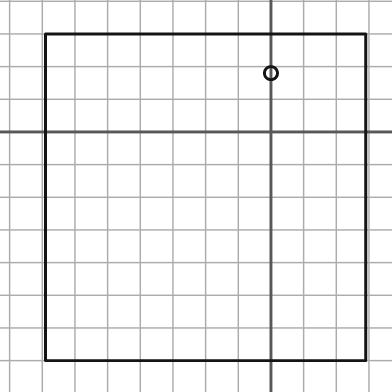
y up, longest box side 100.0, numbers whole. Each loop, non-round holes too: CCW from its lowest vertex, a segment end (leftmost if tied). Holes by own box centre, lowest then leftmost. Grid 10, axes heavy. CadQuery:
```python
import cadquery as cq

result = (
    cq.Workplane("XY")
    .moveTo(-69.0, -70.0)
    .lineTo(29.0, -70.0)
    .lineTo(29.0, 30.0)
    .lineTo(-69.0, 30.0)
    .close()
    .moveTo(0.0, 18.0)
    .circle(2.0)
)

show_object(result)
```